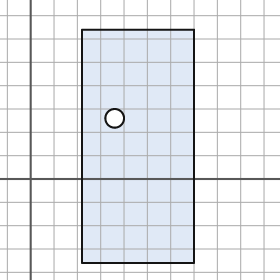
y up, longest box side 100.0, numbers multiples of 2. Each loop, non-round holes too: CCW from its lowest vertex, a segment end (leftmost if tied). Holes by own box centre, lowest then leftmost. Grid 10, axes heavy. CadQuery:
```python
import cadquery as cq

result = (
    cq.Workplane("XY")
    .moveTo(22.0, -36.0)
    .lineTo(70.0, -36.0)
    .lineTo(70.0, 64.0)
    .lineTo(22.0, 64.0)
    .close()
    .moveTo(36.0, 26.0)
    .circle(4.0)
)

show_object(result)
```